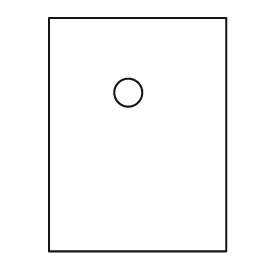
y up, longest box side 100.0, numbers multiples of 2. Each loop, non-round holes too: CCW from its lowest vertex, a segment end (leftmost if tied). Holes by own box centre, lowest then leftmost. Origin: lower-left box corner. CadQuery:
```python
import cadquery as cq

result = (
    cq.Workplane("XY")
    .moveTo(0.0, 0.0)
    .lineTo(76.0, 0.0)
    .lineTo(76.0, 100.0)
    .lineTo(0.0, 100.0)
    .close()
    .moveTo(34.0, 68.0)
    .circle(6.0)
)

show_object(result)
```